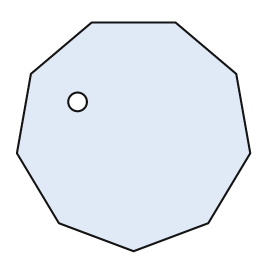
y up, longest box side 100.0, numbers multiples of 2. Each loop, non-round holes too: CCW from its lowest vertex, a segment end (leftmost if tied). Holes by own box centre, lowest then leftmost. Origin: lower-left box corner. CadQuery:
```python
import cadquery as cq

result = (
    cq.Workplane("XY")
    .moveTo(50.0, 0.0)
    .lineTo(82.0, 12.0)
    .lineTo(100.0, 42.0)
    .lineTo(94.0, 76.0)
    .lineTo(68.0, 98.0)
    .lineTo(32.0, 98.0)
    .lineTo(6.0, 76.0)
    .lineTo(0.0, 42.0)
    .lineTo(18.0, 12.0)
    .close()
    .moveTo(26.0, 64.0)
    .circle(4.0)
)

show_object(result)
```